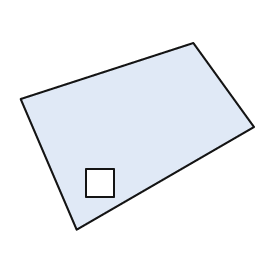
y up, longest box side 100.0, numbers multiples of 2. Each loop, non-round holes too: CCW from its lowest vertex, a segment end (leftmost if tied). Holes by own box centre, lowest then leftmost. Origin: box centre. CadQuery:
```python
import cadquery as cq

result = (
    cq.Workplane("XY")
    .moveTo(-26.0, -40.0)
    .lineTo(50.0, 4.0)
    .lineTo(24.0, 40.0)
    .lineTo(-50.0, 16.0)
    .close()
    .moveTo(-22.0, -26.0)
    .lineTo(-10.0, -26.0)
    .lineTo(-10.0, -14.0)
    .lineTo(-22.0, -14.0)
    .close()
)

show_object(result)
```